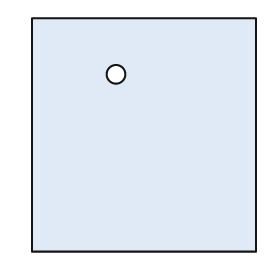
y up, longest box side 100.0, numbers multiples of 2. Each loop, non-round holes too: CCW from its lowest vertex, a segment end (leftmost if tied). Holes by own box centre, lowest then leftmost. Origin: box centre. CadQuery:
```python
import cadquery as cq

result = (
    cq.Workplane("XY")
    .moveTo(-48.0, -50.0)
    .lineTo(48.0, -50.0)
    .lineTo(48.0, 50.0)
    .lineTo(-48.0, 50.0)
    .close()
    .moveTo(-12.0, 26.0)
    .circle(4.0)
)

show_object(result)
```